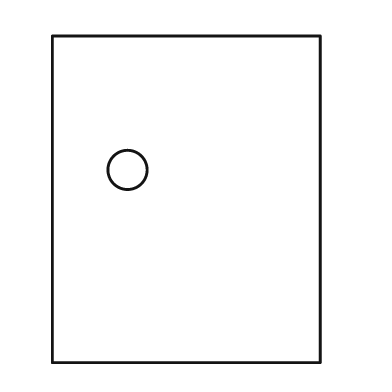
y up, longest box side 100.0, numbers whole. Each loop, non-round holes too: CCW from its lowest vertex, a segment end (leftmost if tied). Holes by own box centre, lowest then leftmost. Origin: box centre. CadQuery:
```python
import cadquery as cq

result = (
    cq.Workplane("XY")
    .moveTo(-41.0, -50.0)
    .lineTo(41.0, -50.0)
    .lineTo(41.0, 50.0)
    .lineTo(-41.0, 50.0)
    .close()
    .moveTo(-18.0, 9.0)
    .circle(6.0)
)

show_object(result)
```